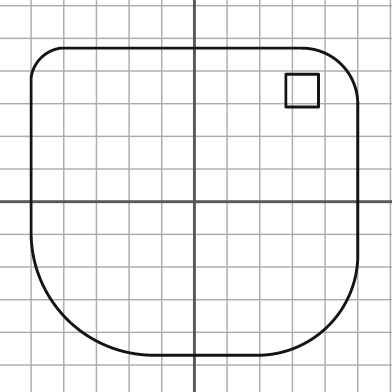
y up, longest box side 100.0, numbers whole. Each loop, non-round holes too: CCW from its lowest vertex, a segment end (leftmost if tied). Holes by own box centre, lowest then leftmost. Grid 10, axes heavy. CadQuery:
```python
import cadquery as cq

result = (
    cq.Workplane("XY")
    .moveTo(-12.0, -47.0)
    .lineTo(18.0, -47.0)
    .threePointArc((41.0, -38.0), (50.0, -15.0))
    .lineTo(50.0, 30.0)
    .threePointArc((45.0, 42.0), (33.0, 47.0))
    .lineTo(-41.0, 47.0)
    .threePointArc((-47.0, 44.0), (-50.0, 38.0))
    .lineTo(-50.0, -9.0)
    .threePointArc((-39.0, -36.0), (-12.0, -47.0))
    .close()
    .moveTo(28.0, 29.0)
    .lineTo(38.0, 29.0)
    .lineTo(38.0, 39.0)
    .lineTo(28.0, 39.0)
    .close()
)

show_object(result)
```